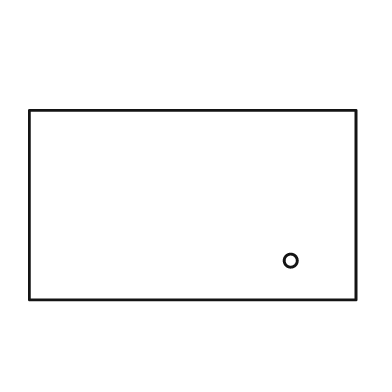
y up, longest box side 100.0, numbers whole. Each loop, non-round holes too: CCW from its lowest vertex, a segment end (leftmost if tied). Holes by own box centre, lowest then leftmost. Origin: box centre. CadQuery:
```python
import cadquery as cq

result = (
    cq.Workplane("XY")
    .moveTo(-50.0, -29.0)
    .lineTo(50.0, -29.0)
    .lineTo(50.0, 29.0)
    .lineTo(-50.0, 29.0)
    .close()
    .moveTo(30.0, -17.0)
    .circle(2.0)
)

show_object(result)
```